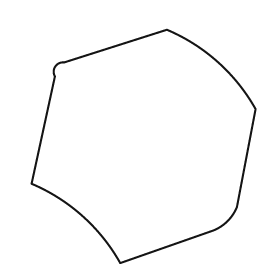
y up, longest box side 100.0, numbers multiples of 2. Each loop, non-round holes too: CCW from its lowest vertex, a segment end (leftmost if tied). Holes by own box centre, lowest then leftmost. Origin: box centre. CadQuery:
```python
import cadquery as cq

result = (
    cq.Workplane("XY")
    .moveTo(-10.0, -50.0)
    .lineTo(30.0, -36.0)
    .threePointArc((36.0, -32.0), (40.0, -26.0))
    .lineTo(48.0, 16.0)
    .threePointArc((32.0, 36.0), (10.0, 50.0))
    .lineTo(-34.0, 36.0)
    .threePointArc((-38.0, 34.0), (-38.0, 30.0))
    .lineTo(-48.0, -16.0)
    .threePointArc((-26.0, -30.0), (-10.0, -50.0))
    .close()
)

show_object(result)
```